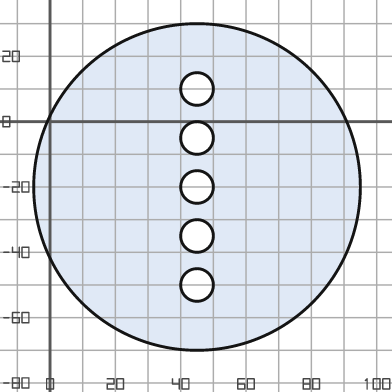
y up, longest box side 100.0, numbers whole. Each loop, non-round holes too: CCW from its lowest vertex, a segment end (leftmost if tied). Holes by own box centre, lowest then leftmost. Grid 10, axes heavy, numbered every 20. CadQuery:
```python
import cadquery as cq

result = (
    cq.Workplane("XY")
    .moveTo(45.0, -20.0)
    .circle(50.0)
    .moveTo(45.0, -50.0)
    .circle(5.0)
    .moveTo(45.0, -35.0)
    .circle(5.0)
    .moveTo(45.0, -20.0)
    .circle(5.0)
    .moveTo(45.0, -5.0)
    .circle(5.0)
    .moveTo(45.0, 10.0)
    .circle(5.0)
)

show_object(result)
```